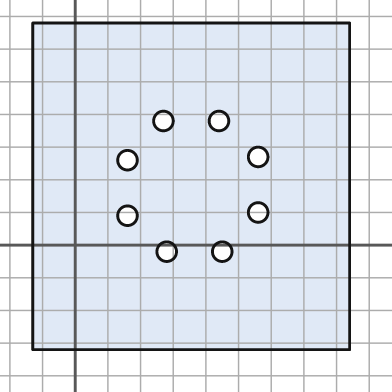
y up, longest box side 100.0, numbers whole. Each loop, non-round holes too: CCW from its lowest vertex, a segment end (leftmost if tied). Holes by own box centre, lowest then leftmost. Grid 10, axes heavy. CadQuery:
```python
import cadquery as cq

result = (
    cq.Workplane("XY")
    .moveTo(-13.0, -32.0)
    .lineTo(84.0, -32.0)
    .lineTo(84.0, 68.0)
    .lineTo(-13.0, 68.0)
    .close()
    .moveTo(28.0, -2.0)
    .circle(3.0)
    .moveTo(45.0, -2.0)
    .circle(3.0)
    .moveTo(16.0, 9.0)
    .circle(3.0)
    .moveTo(56.0, 10.0)
    .circle(3.0)
    .moveTo(16.0, 26.0)
    .circle(3.0)
    .moveTo(56.0, 27.0)
    .circle(3.0)
    .moveTo(27.0, 38.0)
    .circle(3.0)
    .moveTo(44.0, 38.0)
    .circle(3.0)
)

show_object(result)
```